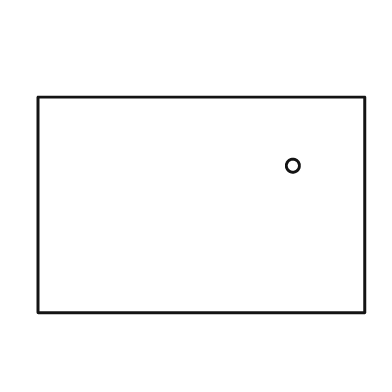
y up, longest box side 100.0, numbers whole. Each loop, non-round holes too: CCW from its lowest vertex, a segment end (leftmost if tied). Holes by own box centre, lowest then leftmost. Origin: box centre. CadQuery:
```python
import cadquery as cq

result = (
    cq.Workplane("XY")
    .moveTo(-50.0, -33.0)
    .lineTo(50.0, -33.0)
    .lineTo(50.0, 33.0)
    .lineTo(-50.0, 33.0)
    .close()
    .moveTo(28.0, 12.0)
    .circle(2.0)
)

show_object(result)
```